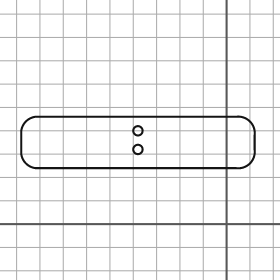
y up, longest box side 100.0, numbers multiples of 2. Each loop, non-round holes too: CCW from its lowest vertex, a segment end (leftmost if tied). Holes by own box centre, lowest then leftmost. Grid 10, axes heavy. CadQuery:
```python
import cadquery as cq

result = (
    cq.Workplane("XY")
    .moveTo(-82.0, 24.0)
    .lineTo(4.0, 24.0)
    .threePointArc((10.0, 26.0), (12.0, 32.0))
    .lineTo(12.0, 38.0)
    .threePointArc((10.0, 44.0), (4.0, 46.0))
    .lineTo(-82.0, 46.0)
    .threePointArc((-86.0, 44.0), (-88.0, 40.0))
    .lineTo(-88.0, 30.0)
    .threePointArc((-86.0, 26.0), (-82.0, 24.0))
    .close()
    .moveTo(-38.0, 32.0)
    .circle(2.0)
    .moveTo(-38.0, 40.0)
    .circle(2.0)
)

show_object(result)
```